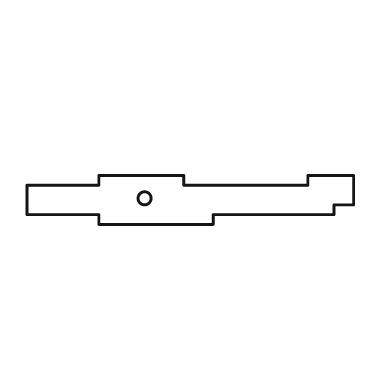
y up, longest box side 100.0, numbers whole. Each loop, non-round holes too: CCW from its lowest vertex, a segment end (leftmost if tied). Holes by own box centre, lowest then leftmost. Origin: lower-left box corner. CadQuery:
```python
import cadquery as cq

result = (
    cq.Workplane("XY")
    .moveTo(22.0, 0.0)
    .lineTo(57.0, 0.0)
    .lineTo(57.0, 3.0)
    .lineTo(94.0, 3.0)
    .lineTo(94.0, 6.0)
    .lineTo(100.0, 6.0)
    .lineTo(100.0, 15.0)
    .lineTo(86.0, 15.0)
    .lineTo(86.0, 12.0)
    .lineTo(48.0, 12.0)
    .lineTo(48.0, 15.0)
    .lineTo(22.0, 15.0)
    .lineTo(22.0, 12.0)
    .lineTo(0.0, 12.0)
    .lineTo(0.0, 3.0)
    .lineTo(22.0, 3.0)
    .close()
    .moveTo(36.0, 8.0)
    .circle(2.0)
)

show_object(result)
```